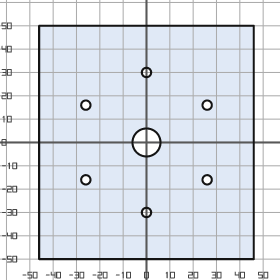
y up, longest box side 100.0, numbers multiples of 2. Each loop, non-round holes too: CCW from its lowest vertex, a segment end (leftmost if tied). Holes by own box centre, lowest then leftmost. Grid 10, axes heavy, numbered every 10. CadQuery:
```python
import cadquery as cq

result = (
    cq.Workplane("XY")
    .moveTo(-46.0, -50.0)
    .lineTo(46.0, -50.0)
    .lineTo(46.0, 50.0)
    .lineTo(-46.0, 50.0)
    .close()
    .moveTo(0.0, -30.0)
    .circle(2.0)
    .moveTo(-26.0, -16.0)
    .circle(2.0)
    .moveTo(26.0, -16.0)
    .circle(2.0)
    .moveTo(0.0, 0.0)
    .circle(6.0)
    .moveTo(-26.0, 16.0)
    .circle(2.0)
    .moveTo(26.0, 16.0)
    .circle(2.0)
    .moveTo(0.0, 30.0)
    .circle(2.0)
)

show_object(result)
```